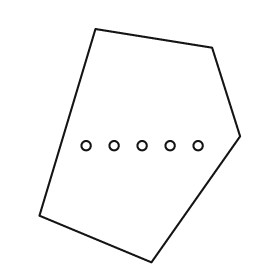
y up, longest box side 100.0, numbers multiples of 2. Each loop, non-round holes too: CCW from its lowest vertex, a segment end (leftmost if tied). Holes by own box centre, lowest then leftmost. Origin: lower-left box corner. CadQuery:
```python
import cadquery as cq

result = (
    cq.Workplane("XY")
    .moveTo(48.0, 0.0)
    .lineTo(86.0, 54.0)
    .lineTo(74.0, 92.0)
    .lineTo(24.0, 100.0)
    .lineTo(0.0, 20.0)
    .close()
    .moveTo(20.0, 50.0)
    .circle(2.0)
    .moveTo(32.0, 50.0)
    .circle(2.0)
    .moveTo(44.0, 50.0)
    .circle(2.0)
    .moveTo(56.0, 50.0)
    .circle(2.0)
    .moveTo(68.0, 50.0)
    .circle(2.0)
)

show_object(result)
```